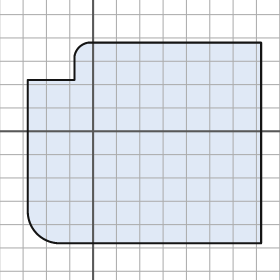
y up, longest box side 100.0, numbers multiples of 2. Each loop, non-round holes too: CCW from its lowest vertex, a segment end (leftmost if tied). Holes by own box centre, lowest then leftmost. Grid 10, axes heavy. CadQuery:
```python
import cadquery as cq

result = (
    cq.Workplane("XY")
    .moveTo(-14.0, -48.0)
    .lineTo(72.0, -48.0)
    .lineTo(72.0, 38.0)
    .lineTo(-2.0, 38.0)
    .threePointArc((-6.0, 36.0), (-8.0, 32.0))
    .lineTo(-8.0, 22.0)
    .lineTo(-28.0, 22.0)
    .lineTo(-28.0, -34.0)
    .threePointArc((-24.0, -44.0), (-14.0, -48.0))
    .close()
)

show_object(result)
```